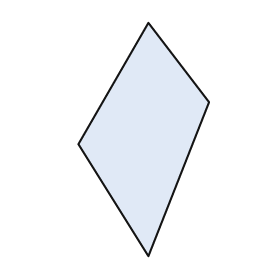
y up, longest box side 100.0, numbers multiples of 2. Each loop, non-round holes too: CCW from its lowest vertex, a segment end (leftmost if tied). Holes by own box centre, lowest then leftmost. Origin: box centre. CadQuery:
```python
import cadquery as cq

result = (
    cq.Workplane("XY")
    .moveTo(2.0, -50.0)
    .lineTo(28.0, 16.0)
    .lineTo(2.0, 50.0)
    .lineTo(-28.0, -2.0)
    .close()
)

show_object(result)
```